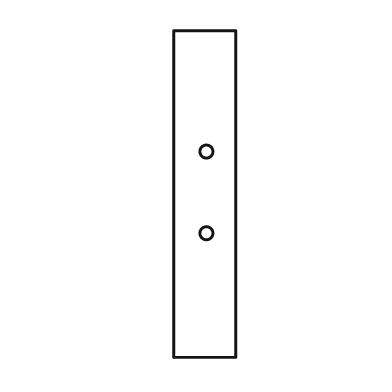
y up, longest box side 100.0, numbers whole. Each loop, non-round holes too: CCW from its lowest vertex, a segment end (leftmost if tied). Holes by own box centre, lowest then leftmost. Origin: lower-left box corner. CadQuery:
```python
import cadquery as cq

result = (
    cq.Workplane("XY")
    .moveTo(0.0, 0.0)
    .lineTo(19.0, 0.0)
    .lineTo(19.0, 100.0)
    .lineTo(0.0, 100.0)
    .close()
    .moveTo(10.0, 38.0)
    .circle(2.0)
    .moveTo(10.0, 63.0)
    .circle(2.0)
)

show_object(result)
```